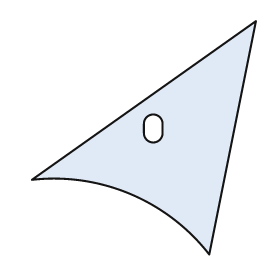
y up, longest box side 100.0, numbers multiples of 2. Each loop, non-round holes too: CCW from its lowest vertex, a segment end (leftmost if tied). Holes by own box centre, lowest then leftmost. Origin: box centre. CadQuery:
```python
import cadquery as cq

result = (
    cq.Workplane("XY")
    .moveTo(28.0, -50.0)
    .lineTo(48.0, 50.0)
    .lineTo(-48.0, -18.0)
    .threePointArc((-6.0, -24.0), (28.0, -50.0))
    .close()
    .moveTo(0.0, 2.0)
    .threePointArc((4.0, -2.0), (8.0, 2.0))
    .lineTo(8.0, 6.0)
    .threePointArc((4.0, 10.0), (0.0, 6.0))
    .close()
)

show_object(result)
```